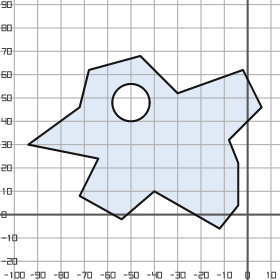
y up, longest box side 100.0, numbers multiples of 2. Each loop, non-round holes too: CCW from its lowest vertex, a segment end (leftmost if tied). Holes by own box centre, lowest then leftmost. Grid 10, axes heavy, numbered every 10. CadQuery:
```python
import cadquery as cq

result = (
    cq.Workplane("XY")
    .moveTo(-12.0, -6.0)
    .lineTo(-4.0, 4.0)
    .lineTo(-4.0, 22.0)
    .lineTo(-8.0, 32.0)
    .lineTo(6.0, 46.0)
    .lineTo(-2.0, 62.0)
    .lineTo(-30.0, 52.0)
    .lineTo(-46.0, 68.0)
    .lineTo(-68.0, 62.0)
    .lineTo(-72.0, 46.0)
    .lineTo(-94.0, 30.0)
    .lineTo(-64.0, 24.0)
    .lineTo(-72.0, 8.0)
    .lineTo(-54.0, -2.0)
    .lineTo(-40.0, 10.0)
    .close()
    .moveTo(-50.0, 48.0)
    .circle(8.0)
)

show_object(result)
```